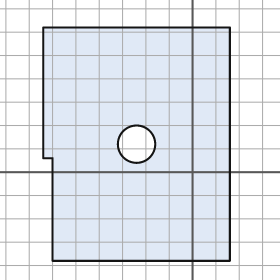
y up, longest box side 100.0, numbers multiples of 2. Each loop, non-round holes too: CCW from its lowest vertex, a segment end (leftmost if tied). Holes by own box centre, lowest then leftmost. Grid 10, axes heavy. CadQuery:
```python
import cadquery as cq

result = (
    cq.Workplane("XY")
    .moveTo(-60.0, -38.0)
    .lineTo(16.0, -38.0)
    .lineTo(16.0, 62.0)
    .lineTo(-64.0, 62.0)
    .lineTo(-64.0, 6.0)
    .lineTo(-60.0, 6.0)
    .close()
    .moveTo(-24.0, 12.0)
    .circle(8.0)
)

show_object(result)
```